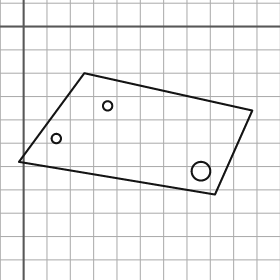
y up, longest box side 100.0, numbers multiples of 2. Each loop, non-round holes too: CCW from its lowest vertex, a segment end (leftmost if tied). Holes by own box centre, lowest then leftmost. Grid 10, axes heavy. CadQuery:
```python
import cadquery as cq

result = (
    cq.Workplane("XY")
    .moveTo(82.0, -72.0)
    .lineTo(98.0, -36.0)
    .lineTo(26.0, -20.0)
    .lineTo(-2.0, -58.0)
    .close()
    .moveTo(76.0, -62.0)
    .circle(4.0)
    .moveTo(14.0, -48.0)
    .circle(2.0)
    .moveTo(36.0, -34.0)
    .circle(2.0)
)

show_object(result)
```